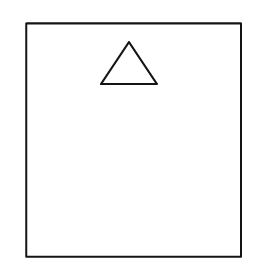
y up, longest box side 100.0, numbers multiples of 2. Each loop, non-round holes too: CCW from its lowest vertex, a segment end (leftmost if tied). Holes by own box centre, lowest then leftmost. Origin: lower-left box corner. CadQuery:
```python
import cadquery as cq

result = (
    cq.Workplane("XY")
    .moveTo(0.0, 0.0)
    .lineTo(92.0, 0.0)
    .lineTo(92.0, 100.0)
    .lineTo(0.0, 100.0)
    .close()
    .moveTo(32.0, 74.0)
    .lineTo(56.0, 74.0)
    .lineTo(44.0, 92.0)
    .close()
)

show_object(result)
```